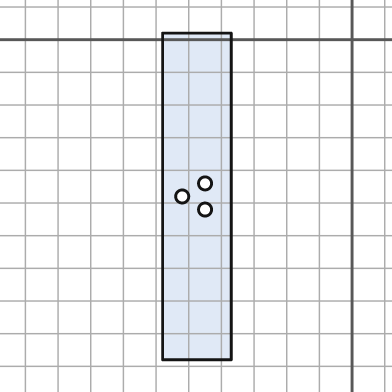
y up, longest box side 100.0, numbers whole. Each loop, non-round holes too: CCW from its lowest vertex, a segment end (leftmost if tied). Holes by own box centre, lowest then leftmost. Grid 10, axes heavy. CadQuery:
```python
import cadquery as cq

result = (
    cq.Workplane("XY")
    .moveTo(-58.0, -98.0)
    .lineTo(-37.0, -98.0)
    .lineTo(-37.0, 2.0)
    .lineTo(-58.0, 2.0)
    .close()
    .moveTo(-45.0, -52.0)
    .circle(2.0)
    .moveTo(-52.0, -48.0)
    .circle(2.0)
    .moveTo(-45.0, -44.0)
    .circle(2.0)
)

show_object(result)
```